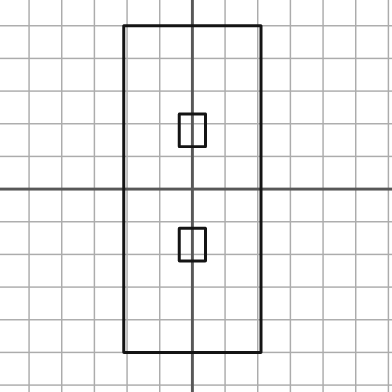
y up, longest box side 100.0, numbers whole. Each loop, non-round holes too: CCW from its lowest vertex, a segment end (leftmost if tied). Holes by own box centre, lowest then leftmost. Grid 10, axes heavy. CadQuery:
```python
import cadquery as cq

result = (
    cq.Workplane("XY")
    .moveTo(-21.0, -50.0)
    .lineTo(21.0, -50.0)
    .lineTo(21.0, 50.0)
    .lineTo(-21.0, 50.0)
    .close()
    .moveTo(-4.0, -22.0)
    .lineTo(4.0, -22.0)
    .lineTo(4.0, -12.0)
    .lineTo(-4.0, -12.0)
    .close()
    .moveTo(-4.0, 13.0)
    .lineTo(4.0, 13.0)
    .lineTo(4.0, 23.0)
    .lineTo(-4.0, 23.0)
    .close()
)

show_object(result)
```